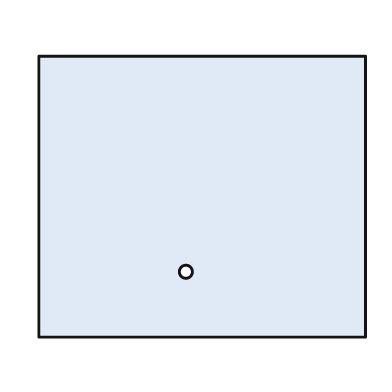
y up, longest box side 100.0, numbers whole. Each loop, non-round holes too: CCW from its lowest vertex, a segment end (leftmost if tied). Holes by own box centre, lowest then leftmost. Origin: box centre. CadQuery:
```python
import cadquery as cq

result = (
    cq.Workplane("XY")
    .moveTo(-50.0, -43.0)
    .lineTo(50.0, -43.0)
    .lineTo(50.0, 43.0)
    .lineTo(-50.0, 43.0)
    .close()
    .moveTo(-5.0, -23.0)
    .circle(2.0)
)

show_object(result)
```